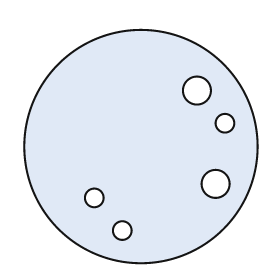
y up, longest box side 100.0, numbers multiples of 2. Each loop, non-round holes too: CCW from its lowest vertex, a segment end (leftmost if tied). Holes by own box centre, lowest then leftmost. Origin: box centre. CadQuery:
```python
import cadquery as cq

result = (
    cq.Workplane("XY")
    .moveTo(0.0, 0.0)
    .circle(50.0)
    .moveTo(-8.0, -36.0)
    .circle(4.0)
    .moveTo(-20.0, -22.0)
    .circle(4.0)
    .moveTo(32.0, -16.0)
    .circle(6.0)
    .moveTo(36.0, 10.0)
    .circle(4.0)
    .moveTo(24.0, 24.0)
    .circle(6.0)
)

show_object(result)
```